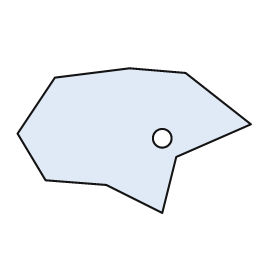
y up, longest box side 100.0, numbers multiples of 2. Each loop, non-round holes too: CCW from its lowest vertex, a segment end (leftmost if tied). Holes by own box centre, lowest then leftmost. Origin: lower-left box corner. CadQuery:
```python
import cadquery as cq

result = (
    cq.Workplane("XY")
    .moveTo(62.0, 0.0)
    .lineTo(68.0, 24.0)
    .lineTo(100.0, 38.0)
    .lineTo(72.0, 60.0)
    .lineTo(48.0, 62.0)
    .lineTo(16.0, 58.0)
    .lineTo(0.0, 34.0)
    .lineTo(12.0, 14.0)
    .lineTo(38.0, 12.0)
    .close()
    .moveTo(62.0, 32.0)
    .circle(4.0)
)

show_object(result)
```